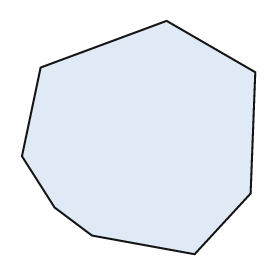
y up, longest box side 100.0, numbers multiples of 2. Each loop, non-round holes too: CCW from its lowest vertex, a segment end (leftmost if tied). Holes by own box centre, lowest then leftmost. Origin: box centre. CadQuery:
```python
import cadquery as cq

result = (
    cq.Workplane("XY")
    .moveTo(24.0, -50.0)
    .lineTo(48.0, -24.0)
    .lineTo(50.0, 28.0)
    .lineTo(12.0, 50.0)
    .lineTo(-42.0, 30.0)
    .lineTo(-50.0, -8.0)
    .lineTo(-36.0, -30.0)
    .lineTo(-20.0, -42.0)
    .close()
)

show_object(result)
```